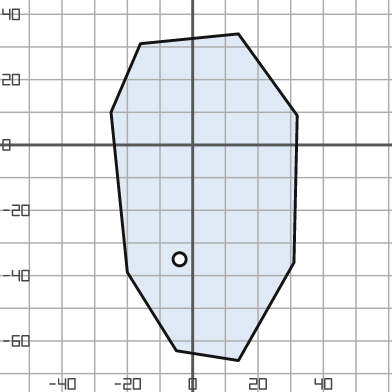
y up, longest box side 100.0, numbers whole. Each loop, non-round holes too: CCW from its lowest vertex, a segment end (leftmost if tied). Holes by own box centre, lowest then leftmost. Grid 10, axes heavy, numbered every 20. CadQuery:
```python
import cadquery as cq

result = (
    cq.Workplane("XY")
    .moveTo(14.0, -66.0)
    .lineTo(31.0, -36.0)
    .lineTo(32.0, 9.0)
    .lineTo(14.0, 34.0)
    .lineTo(-16.0, 31.0)
    .lineTo(-25.0, 10.0)
    .lineTo(-20.0, -39.0)
    .lineTo(-5.0, -63.0)
    .close()
    .moveTo(-4.0, -35.0)
    .circle(2.0)
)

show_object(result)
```